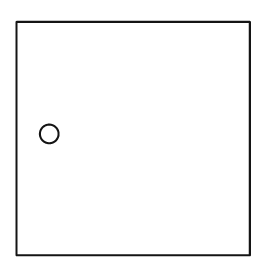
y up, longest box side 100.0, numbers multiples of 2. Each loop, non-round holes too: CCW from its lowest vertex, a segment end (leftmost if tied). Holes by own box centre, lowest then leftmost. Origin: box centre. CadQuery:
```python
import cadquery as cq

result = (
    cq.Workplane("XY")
    .moveTo(-50.0, -50.0)
    .lineTo(50.0, -50.0)
    .lineTo(50.0, 50.0)
    .lineTo(-50.0, 50.0)
    .close()
    .moveTo(-36.0, 2.0)
    .circle(4.0)
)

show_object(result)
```